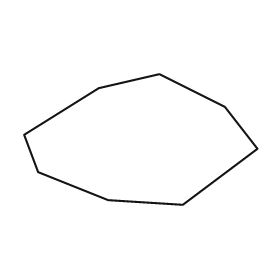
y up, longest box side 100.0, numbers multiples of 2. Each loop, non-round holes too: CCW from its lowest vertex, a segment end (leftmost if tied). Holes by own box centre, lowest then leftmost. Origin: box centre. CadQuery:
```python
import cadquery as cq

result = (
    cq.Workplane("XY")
    .moveTo(18.0, -28.0)
    .lineTo(50.0, -4.0)
    .lineTo(36.0, 14.0)
    .lineTo(8.0, 28.0)
    .lineTo(-18.0, 22.0)
    .lineTo(-50.0, 2.0)
    .lineTo(-44.0, -14.0)
    .lineTo(-14.0, -26.0)
    .close()
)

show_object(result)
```